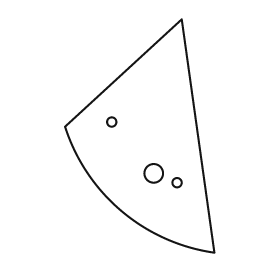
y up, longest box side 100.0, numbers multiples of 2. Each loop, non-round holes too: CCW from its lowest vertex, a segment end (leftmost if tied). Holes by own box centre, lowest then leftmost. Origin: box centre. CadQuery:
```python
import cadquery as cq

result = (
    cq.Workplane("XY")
    .moveTo(32.0, -50.0)
    .lineTo(18.0, 50.0)
    .lineTo(-32.0, 4.0)
    .threePointArc((-8.0, -32.0), (32.0, -50.0))
    .close()
    .moveTo(16.0, -20.0)
    .circle(2.0)
    .moveTo(6.0, -16.0)
    .circle(4.0)
    .moveTo(-12.0, 6.0)
    .circle(2.0)
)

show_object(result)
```